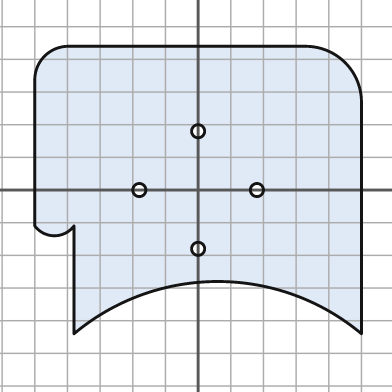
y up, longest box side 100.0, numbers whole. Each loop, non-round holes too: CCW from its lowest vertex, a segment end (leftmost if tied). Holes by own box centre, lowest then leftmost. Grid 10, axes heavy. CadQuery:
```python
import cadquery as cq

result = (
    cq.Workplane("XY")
    .moveTo(-38.0, -44.0)
    .threePointArc((6.0, -28.0), (50.0, -44.0))
    .lineTo(50.0, 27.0)
    .threePointArc((45.0, 39.0), (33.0, 44.0))
    .lineTo(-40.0, 44.0)
    .threePointArc((-47.0, 41.0), (-50.0, 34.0))
    .lineTo(-50.0, -11.0)
    .threePointArc((-44.0, -14.0), (-38.0, -11.0))
    .close()
    .moveTo(0.0, -18.0)
    .circle(2.0)
    .moveTo(-18.0, 0.0)
    .circle(2.0)
    .moveTo(18.0, 0.0)
    .circle(2.0)
    .moveTo(0.0, 18.0)
    .circle(2.0)
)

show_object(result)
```